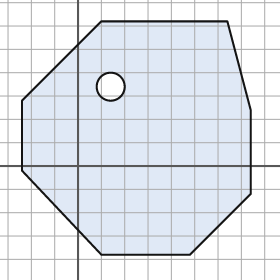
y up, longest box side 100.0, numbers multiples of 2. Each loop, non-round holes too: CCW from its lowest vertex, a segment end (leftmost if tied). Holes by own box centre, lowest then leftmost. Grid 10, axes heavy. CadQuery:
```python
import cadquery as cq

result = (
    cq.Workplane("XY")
    .moveTo(10.0, -38.0)
    .lineTo(48.0, -38.0)
    .lineTo(74.0, -12.0)
    .lineTo(74.0, 24.0)
    .lineTo(64.0, 62.0)
    .lineTo(10.0, 62.0)
    .lineTo(-24.0, 28.0)
    .lineTo(-24.0, -2.0)
    .close()
    .moveTo(14.0, 34.0)
    .circle(6.0)
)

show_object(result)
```